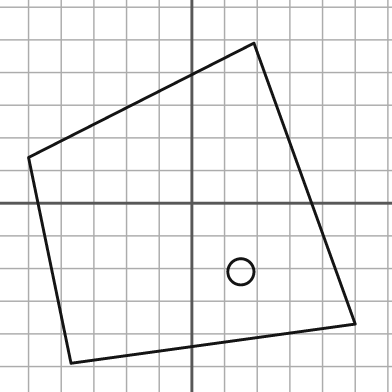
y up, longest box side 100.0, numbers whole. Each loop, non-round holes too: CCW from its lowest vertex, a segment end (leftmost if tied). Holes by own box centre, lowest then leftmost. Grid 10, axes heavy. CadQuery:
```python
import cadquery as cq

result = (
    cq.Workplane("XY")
    .moveTo(-37.0, -49.0)
    .lineTo(50.0, -37.0)
    .lineTo(19.0, 49.0)
    .lineTo(-50.0, 14.0)
    .close()
    .moveTo(15.0, -21.0)
    .circle(4.0)
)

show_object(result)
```